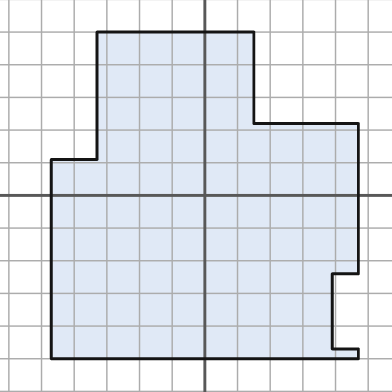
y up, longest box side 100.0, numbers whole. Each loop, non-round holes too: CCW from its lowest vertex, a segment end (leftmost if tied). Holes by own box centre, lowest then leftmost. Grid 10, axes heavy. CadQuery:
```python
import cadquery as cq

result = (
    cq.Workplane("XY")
    .moveTo(-47.0, -50.0)
    .lineTo(47.0, -50.0)
    .lineTo(47.0, -47.0)
    .lineTo(39.0, -47.0)
    .lineTo(39.0, -24.0)
    .lineTo(47.0, -24.0)
    .lineTo(47.0, 22.0)
    .lineTo(15.0, 22.0)
    .lineTo(15.0, 50.0)
    .lineTo(-33.0, 50.0)
    .lineTo(-33.0, 11.0)
    .lineTo(-47.0, 11.0)
    .close()
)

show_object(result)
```